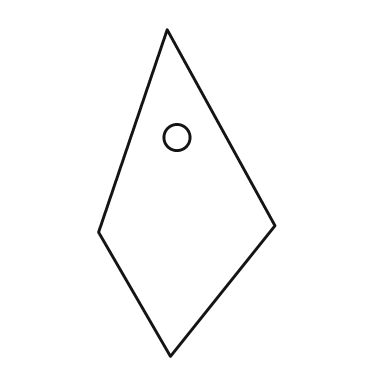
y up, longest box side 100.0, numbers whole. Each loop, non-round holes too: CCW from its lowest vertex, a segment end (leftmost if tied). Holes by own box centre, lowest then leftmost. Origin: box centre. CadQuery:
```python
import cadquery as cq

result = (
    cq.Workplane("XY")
    .moveTo(-5.0, -50.0)
    .lineTo(27.0, -10.0)
    .lineTo(-6.0, 50.0)
    .lineTo(-27.0, -12.0)
    .close()
    .moveTo(-3.0, 17.0)
    .circle(4.0)
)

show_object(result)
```